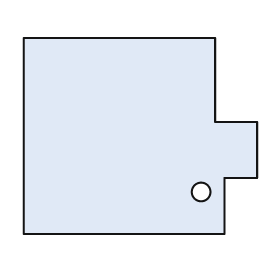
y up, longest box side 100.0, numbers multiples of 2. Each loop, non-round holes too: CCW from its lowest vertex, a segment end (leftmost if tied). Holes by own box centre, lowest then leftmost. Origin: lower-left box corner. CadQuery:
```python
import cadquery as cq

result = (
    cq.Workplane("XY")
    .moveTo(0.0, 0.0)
    .lineTo(86.0, 0.0)
    .lineTo(86.0, 24.0)
    .lineTo(100.0, 24.0)
    .lineTo(100.0, 48.0)
    .lineTo(82.0, 48.0)
    .lineTo(82.0, 84.0)
    .lineTo(0.0, 84.0)
    .close()
    .moveTo(76.0, 18.0)
    .circle(4.0)
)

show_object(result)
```